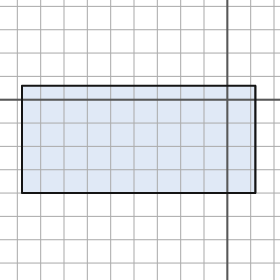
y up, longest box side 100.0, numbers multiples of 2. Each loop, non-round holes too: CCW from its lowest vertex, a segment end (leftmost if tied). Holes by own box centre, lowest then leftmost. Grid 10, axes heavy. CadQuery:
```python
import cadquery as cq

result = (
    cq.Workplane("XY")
    .moveTo(-88.0, -40.0)
    .lineTo(12.0, -40.0)
    .lineTo(12.0, 6.0)
    .lineTo(-88.0, 6.0)
    .close()
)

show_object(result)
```